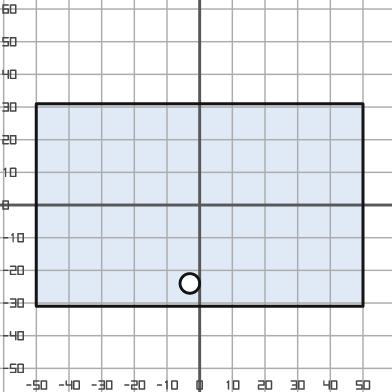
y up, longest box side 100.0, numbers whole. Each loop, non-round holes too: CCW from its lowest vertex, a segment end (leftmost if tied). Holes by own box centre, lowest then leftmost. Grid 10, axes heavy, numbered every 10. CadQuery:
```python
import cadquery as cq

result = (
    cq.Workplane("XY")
    .moveTo(-50.0, -31.0)
    .lineTo(50.0, -31.0)
    .lineTo(50.0, 31.0)
    .lineTo(-50.0, 31.0)
    .close()
    .moveTo(-3.0, -24.0)
    .circle(3.0)
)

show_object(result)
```